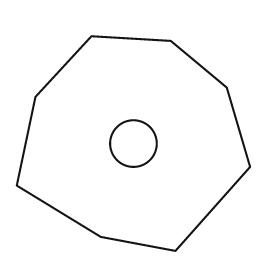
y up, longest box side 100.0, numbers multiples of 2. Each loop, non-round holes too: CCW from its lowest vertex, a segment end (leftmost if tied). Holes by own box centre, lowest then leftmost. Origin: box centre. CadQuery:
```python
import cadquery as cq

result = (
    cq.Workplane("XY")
    .moveTo(18.0, -46.0)
    .lineTo(50.0, -10.0)
    .lineTo(40.0, 24.0)
    .lineTo(16.0, 44.0)
    .lineTo(-18.0, 46.0)
    .lineTo(-42.0, 20.0)
    .lineTo(-50.0, -18.0)
    .lineTo(-14.0, -40.0)
    .close()
    .moveTo(0.0, 0.0)
    .circle(10.0)
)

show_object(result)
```